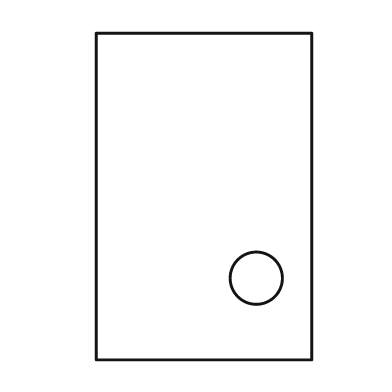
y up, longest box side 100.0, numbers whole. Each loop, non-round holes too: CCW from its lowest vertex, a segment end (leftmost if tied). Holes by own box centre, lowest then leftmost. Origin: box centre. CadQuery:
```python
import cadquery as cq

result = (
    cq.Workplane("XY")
    .moveTo(-33.0, -50.0)
    .lineTo(33.0, -50.0)
    .lineTo(33.0, 50.0)
    .lineTo(-33.0, 50.0)
    .close()
    .moveTo(16.0, -25.0)
    .circle(8.0)
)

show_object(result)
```